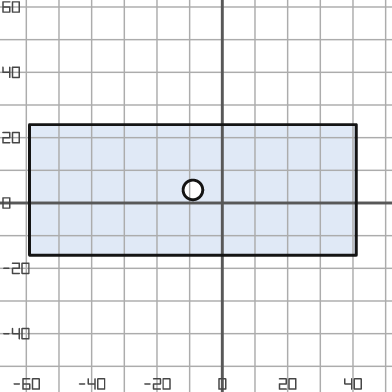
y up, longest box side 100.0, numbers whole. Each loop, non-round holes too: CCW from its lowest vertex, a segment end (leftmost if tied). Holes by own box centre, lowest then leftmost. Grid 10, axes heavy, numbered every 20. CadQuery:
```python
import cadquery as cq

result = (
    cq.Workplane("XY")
    .moveTo(-59.0, -16.0)
    .lineTo(41.0, -16.0)
    .lineTo(41.0, 24.0)
    .lineTo(-59.0, 24.0)
    .close()
    .moveTo(-9.0, 4.0)
    .circle(3.0)
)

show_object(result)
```